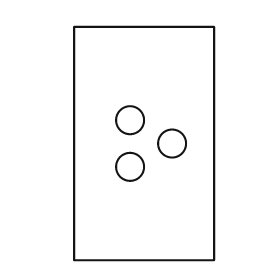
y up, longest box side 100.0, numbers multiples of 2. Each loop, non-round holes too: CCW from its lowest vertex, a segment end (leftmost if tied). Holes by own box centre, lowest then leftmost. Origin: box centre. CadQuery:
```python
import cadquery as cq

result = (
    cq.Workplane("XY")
    .moveTo(-30.0, -50.0)
    .lineTo(30.0, -50.0)
    .lineTo(30.0, 50.0)
    .lineTo(-30.0, 50.0)
    .close()
    .moveTo(-6.0, -10.0)
    .circle(6.0)
    .moveTo(12.0, 0.0)
    .circle(6.0)
    .moveTo(-6.0, 10.0)
    .circle(6.0)
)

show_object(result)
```